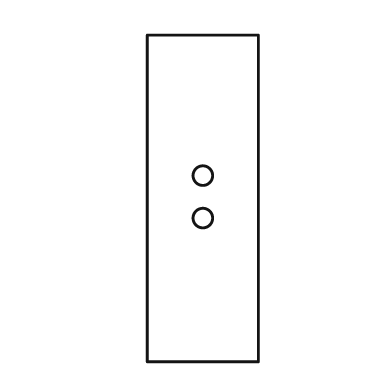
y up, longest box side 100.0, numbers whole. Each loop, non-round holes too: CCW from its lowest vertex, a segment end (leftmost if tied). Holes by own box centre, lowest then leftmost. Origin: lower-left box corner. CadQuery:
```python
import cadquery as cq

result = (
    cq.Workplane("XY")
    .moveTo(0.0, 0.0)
    .lineTo(34.0, 0.0)
    .lineTo(34.0, 100.0)
    .lineTo(0.0, 100.0)
    .close()
    .moveTo(17.0, 44.0)
    .circle(3.0)
    .moveTo(17.0, 57.0)
    .circle(3.0)
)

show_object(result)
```